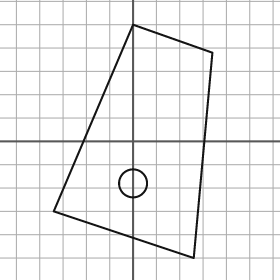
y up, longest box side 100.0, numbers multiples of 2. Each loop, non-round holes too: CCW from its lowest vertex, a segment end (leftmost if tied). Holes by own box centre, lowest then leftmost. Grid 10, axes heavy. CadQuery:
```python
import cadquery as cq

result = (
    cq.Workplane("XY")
    .moveTo(26.0, -50.0)
    .lineTo(34.0, 38.0)
    .lineTo(0.0, 50.0)
    .lineTo(-34.0, -30.0)
    .close()
    .moveTo(0.0, -18.0)
    .circle(6.0)
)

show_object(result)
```